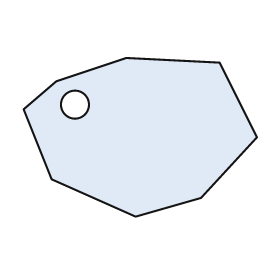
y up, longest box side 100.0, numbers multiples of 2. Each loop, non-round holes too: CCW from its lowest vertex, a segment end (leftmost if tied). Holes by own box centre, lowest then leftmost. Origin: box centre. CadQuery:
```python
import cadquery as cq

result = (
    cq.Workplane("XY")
    .moveTo(-2.0, -34.0)
    .lineTo(26.0, -26.0)
    .lineTo(50.0, 0.0)
    .lineTo(34.0, 32.0)
    .lineTo(-6.0, 34.0)
    .lineTo(-36.0, 24.0)
    .lineTo(-50.0, 12.0)
    .lineTo(-38.0, -18.0)
    .close()
    .moveTo(-28.0, 14.0)
    .circle(6.0)
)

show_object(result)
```